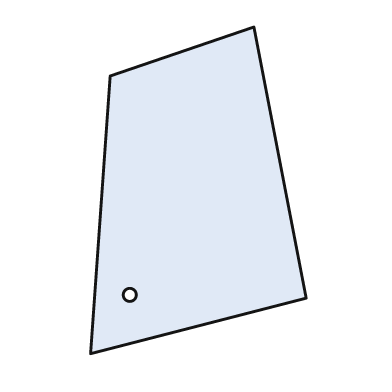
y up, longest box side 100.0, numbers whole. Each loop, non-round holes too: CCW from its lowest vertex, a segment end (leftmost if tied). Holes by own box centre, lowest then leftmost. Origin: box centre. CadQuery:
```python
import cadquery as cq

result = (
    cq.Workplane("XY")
    .moveTo(-33.0, -50.0)
    .lineTo(33.0, -33.0)
    .lineTo(17.0, 50.0)
    .lineTo(-27.0, 35.0)
    .close()
    .moveTo(-21.0, -32.0)
    .circle(2.0)
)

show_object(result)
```